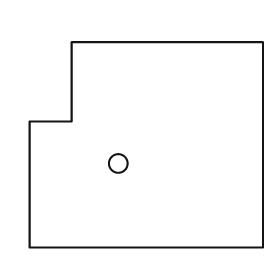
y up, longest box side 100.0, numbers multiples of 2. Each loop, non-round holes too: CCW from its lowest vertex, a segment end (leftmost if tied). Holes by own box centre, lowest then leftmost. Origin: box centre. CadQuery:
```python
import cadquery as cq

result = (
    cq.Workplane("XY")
    .moveTo(-50.0, -44.0)
    .lineTo(50.0, -44.0)
    .lineTo(50.0, 44.0)
    .lineTo(-32.0, 44.0)
    .lineTo(-32.0, 10.0)
    .lineTo(-50.0, 10.0)
    .close()
    .moveTo(-12.0, -8.0)
    .circle(4.0)
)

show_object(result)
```